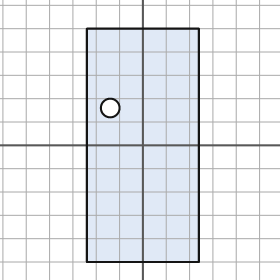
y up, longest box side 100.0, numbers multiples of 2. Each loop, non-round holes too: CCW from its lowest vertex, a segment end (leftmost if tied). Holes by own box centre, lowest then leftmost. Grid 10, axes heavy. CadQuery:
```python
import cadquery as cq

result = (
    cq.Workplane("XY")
    .moveTo(-24.0, -50.0)
    .lineTo(24.0, -50.0)
    .lineTo(24.0, 50.0)
    .lineTo(-24.0, 50.0)
    .close()
    .moveTo(-14.0, 16.0)
    .circle(4.0)
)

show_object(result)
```